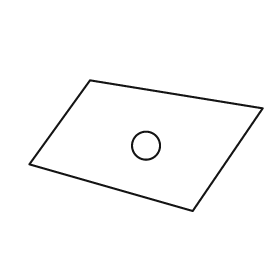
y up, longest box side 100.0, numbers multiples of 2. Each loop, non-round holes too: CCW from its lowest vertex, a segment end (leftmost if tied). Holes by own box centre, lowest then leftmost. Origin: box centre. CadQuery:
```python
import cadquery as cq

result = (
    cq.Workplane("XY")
    .moveTo(20.0, -28.0)
    .lineTo(50.0, 16.0)
    .lineTo(-24.0, 28.0)
    .lineTo(-50.0, -8.0)
    .close()
    .moveTo(0.0, 0.0)
    .circle(6.0)
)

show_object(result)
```